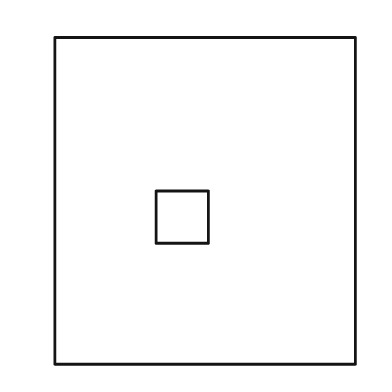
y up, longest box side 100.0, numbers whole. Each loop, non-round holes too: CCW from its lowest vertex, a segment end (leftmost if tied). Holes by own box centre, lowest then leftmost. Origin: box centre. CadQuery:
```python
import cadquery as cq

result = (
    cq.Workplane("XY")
    .moveTo(-46.0, -50.0)
    .lineTo(46.0, -50.0)
    .lineTo(46.0, 50.0)
    .lineTo(-46.0, 50.0)
    .close()
    .moveTo(-15.0, -13.0)
    .lineTo(1.0, -13.0)
    .lineTo(1.0, 3.0)
    .lineTo(-15.0, 3.0)
    .close()
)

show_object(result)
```